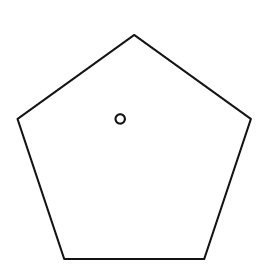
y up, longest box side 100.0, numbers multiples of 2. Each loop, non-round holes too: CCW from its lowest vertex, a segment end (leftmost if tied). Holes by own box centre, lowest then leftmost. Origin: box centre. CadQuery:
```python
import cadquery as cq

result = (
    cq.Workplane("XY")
    .moveTo(-30.0, -48.0)
    .lineTo(30.0, -48.0)
    .lineTo(50.0, 12.0)
    .lineTo(0.0, 48.0)
    .lineTo(-50.0, 12.0)
    .close()
    .moveTo(-6.0, 12.0)
    .circle(2.0)
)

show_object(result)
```